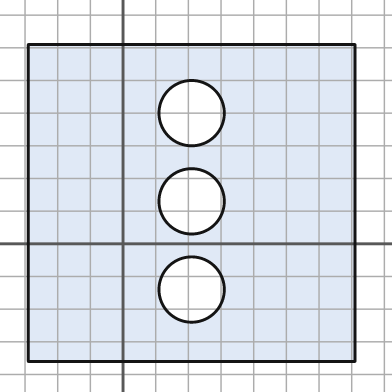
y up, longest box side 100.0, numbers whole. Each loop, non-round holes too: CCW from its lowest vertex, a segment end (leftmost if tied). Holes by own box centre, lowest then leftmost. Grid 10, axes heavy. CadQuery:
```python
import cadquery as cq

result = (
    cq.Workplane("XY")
    .moveTo(-29.0, -36.0)
    .lineTo(71.0, -36.0)
    .lineTo(71.0, 61.0)
    .lineTo(-29.0, 61.0)
    .close()
    .moveTo(21.0, -14.0)
    .circle(10.0)
    .moveTo(21.0, 13.0)
    .circle(10.0)
    .moveTo(21.0, 40.0)
    .circle(10.0)
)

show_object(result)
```